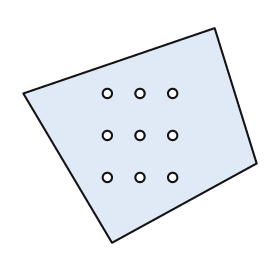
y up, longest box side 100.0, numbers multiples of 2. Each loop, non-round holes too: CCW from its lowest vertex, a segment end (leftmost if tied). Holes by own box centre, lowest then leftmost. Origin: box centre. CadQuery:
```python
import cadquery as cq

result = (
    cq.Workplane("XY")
    .moveTo(-12.0, -46.0)
    .lineTo(50.0, -12.0)
    .lineTo(32.0, 46.0)
    .lineTo(-50.0, 18.0)
    .close()
    .moveTo(-14.0, -18.0)
    .circle(2.0)
    .moveTo(0.0, -18.0)
    .circle(2.0)
    .moveTo(14.0, -18.0)
    .circle(2.0)
    .moveTo(-14.0, 0.0)
    .circle(2.0)
    .moveTo(0.0, 0.0)
    .circle(2.0)
    .moveTo(14.0, 0.0)
    .circle(2.0)
    .moveTo(-14.0, 18.0)
    .circle(2.0)
    .moveTo(0.0, 18.0)
    .circle(2.0)
    .moveTo(14.0, 18.0)
    .circle(2.0)
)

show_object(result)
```